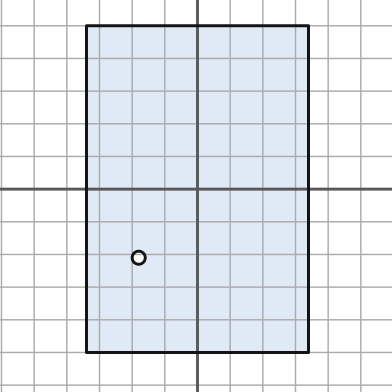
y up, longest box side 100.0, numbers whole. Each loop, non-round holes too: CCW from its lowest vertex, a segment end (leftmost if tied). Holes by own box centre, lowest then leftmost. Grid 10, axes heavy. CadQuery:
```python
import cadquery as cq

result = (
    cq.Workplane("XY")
    .moveTo(-34.0, -50.0)
    .lineTo(34.0, -50.0)
    .lineTo(34.0, 50.0)
    .lineTo(-34.0, 50.0)
    .close()
    .moveTo(-18.0, -21.0)
    .circle(2.0)
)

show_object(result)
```